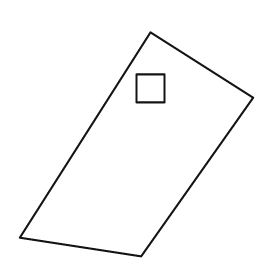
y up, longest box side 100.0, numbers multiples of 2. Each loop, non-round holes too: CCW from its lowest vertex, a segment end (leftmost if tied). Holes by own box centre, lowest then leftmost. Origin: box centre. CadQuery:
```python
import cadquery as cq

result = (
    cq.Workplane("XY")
    .moveTo(2.0, -48.0)
    .lineTo(50.0, 20.0)
    .lineTo(6.0, 48.0)
    .lineTo(-50.0, -40.0)
    .close()
    .moveTo(0.0, 18.0)
    .lineTo(12.0, 18.0)
    .lineTo(12.0, 30.0)
    .lineTo(0.0, 30.0)
    .close()
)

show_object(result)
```